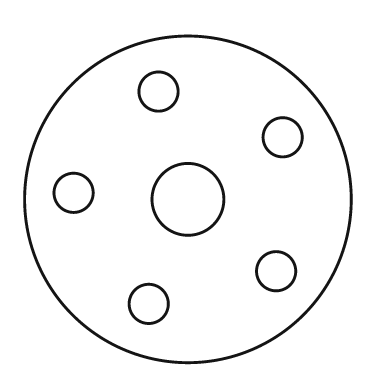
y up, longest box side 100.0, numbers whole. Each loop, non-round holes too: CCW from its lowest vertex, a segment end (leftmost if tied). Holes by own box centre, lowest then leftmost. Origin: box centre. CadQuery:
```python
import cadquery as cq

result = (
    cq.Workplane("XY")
    .moveTo(0.0, 0.0)
    .circle(50.0)
    .moveTo(-12.0, -32.0)
    .circle(6.0)
    .moveTo(27.0, -22.0)
    .circle(6.0)
    .moveTo(0.0, 0.0)
    .circle(11.0)
    .moveTo(-35.0, 2.0)
    .circle(6.0)
    .moveTo(29.0, 19.0)
    .circle(6.0)
    .moveTo(-9.0, 33.0)
    .circle(6.0)
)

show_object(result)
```